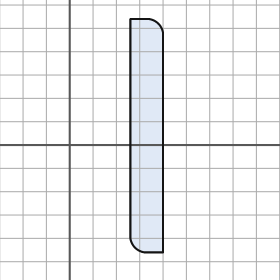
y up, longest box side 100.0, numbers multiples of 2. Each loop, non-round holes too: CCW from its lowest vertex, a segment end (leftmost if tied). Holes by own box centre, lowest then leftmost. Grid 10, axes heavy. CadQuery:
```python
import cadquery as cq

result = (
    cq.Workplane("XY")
    .moveTo(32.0, -46.0)
    .lineTo(40.0, -46.0)
    .lineTo(40.0, 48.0)
    .threePointArc((38.0, 52.0), (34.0, 54.0))
    .lineTo(26.0, 54.0)
    .lineTo(26.0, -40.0)
    .threePointArc((28.0, -44.0), (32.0, -46.0))
    .close()
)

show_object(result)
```